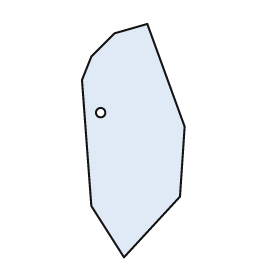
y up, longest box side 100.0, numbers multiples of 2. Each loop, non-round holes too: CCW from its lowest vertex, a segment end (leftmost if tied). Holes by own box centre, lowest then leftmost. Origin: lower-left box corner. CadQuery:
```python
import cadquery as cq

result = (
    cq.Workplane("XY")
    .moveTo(18.0, 0.0)
    .lineTo(42.0, 26.0)
    .lineTo(44.0, 56.0)
    .lineTo(28.0, 100.0)
    .lineTo(14.0, 96.0)
    .lineTo(4.0, 86.0)
    .lineTo(0.0, 76.0)
    .lineTo(4.0, 22.0)
    .close()
    .moveTo(8.0, 62.0)
    .circle(2.0)
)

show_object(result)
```